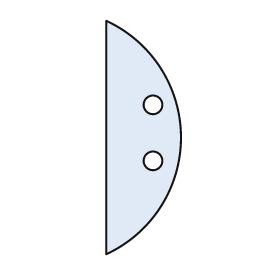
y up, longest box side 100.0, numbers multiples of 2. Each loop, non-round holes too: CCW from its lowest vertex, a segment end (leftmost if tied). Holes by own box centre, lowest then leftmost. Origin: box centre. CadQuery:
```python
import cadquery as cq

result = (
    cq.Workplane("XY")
    .moveTo(-16.0, -50.0)
    .threePointArc((16.0, 0.0), (-16.0, 50.0))
    .close()
    .moveTo(4.0, -10.0)
    .circle(4.0)
    .moveTo(4.0, 14.0)
    .circle(4.0)
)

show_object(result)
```